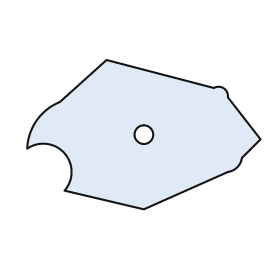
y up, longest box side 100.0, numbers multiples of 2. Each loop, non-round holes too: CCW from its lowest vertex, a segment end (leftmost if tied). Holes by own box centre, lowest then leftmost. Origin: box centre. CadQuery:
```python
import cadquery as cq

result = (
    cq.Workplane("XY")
    .moveTo(0.0, -32.0)
    .lineTo(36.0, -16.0)
    .threePointArc((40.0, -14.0), (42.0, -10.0))
    .lineTo(50.0, -2.0)
    .lineTo(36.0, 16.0)
    .threePointArc((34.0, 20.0), (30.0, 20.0))
    .lineTo(-16.0, 32.0)
    .lineTo(-36.0, 14.0)
    .threePointArc((-46.0, 6.0), (-50.0, -6.0))
    .threePointArc((-34.0, -8.0), (-34.0, -24.0))
    .close()
    .moveTo(0.0, 0.0)
    .circle(4.0)
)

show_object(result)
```